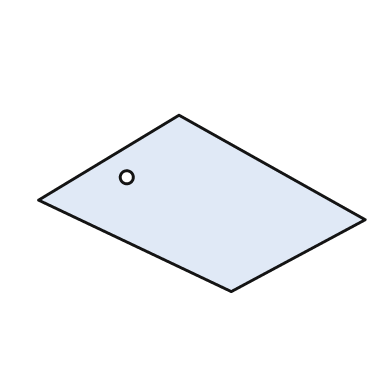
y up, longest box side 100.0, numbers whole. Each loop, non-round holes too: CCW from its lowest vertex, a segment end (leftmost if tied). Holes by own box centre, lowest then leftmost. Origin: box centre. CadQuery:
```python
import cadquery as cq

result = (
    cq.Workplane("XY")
    .moveTo(9.0, -27.0)
    .lineTo(50.0, -5.0)
    .lineTo(-7.0, 27.0)
    .lineTo(-50.0, 1.0)
    .close()
    .moveTo(-23.0, 8.0)
    .circle(2.0)
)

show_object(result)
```